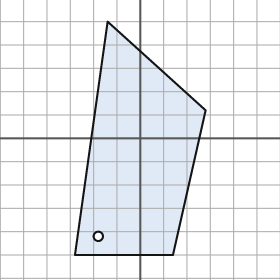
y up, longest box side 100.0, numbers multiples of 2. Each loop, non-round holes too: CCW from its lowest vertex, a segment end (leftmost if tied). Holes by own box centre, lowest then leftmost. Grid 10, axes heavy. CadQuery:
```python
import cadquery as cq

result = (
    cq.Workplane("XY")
    .moveTo(-28.0, -50.0)
    .lineTo(14.0, -50.0)
    .lineTo(28.0, 12.0)
    .lineTo(-14.0, 50.0)
    .close()
    .moveTo(-18.0, -42.0)
    .circle(2.0)
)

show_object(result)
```